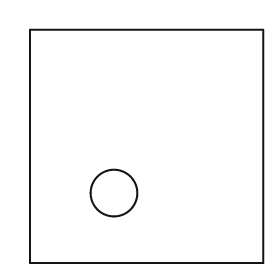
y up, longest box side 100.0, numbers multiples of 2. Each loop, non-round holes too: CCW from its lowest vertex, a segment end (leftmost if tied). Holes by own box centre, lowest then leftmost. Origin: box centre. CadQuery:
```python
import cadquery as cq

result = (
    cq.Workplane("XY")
    .moveTo(-50.0, -50.0)
    .lineTo(50.0, -50.0)
    .lineTo(50.0, 50.0)
    .lineTo(-50.0, 50.0)
    .close()
    .moveTo(-14.0, -20.0)
    .circle(10.0)
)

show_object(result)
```